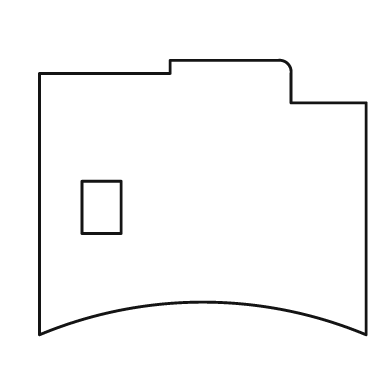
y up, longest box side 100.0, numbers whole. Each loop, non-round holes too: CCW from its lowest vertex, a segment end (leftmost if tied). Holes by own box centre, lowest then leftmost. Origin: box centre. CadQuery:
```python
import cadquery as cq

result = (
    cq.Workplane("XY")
    .moveTo(-50.0, -42.0)
    .threePointArc((0.0, -32.0), (50.0, -42.0))
    .lineTo(50.0, 29.0)
    .lineTo(27.0, 29.0)
    .lineTo(27.0, 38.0)
    .threePointArc((26.0, 41.0), (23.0, 42.0))
    .lineTo(-10.0, 42.0)
    .lineTo(-10.0, 38.0)
    .lineTo(-50.0, 38.0)
    .close()
    .moveTo(-37.0, -11.0)
    .lineTo(-25.0, -11.0)
    .lineTo(-25.0, 5.0)
    .lineTo(-37.0, 5.0)
    .close()
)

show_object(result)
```